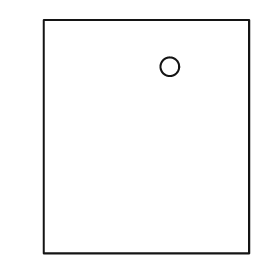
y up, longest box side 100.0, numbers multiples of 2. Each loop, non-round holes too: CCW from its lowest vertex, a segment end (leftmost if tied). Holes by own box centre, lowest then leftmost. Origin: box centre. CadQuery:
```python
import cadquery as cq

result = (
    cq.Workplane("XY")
    .moveTo(-44.0, -50.0)
    .lineTo(44.0, -50.0)
    .lineTo(44.0, 50.0)
    .lineTo(-44.0, 50.0)
    .close()
    .moveTo(10.0, 30.0)
    .circle(4.0)
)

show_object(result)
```